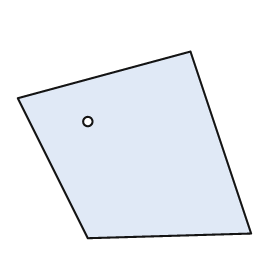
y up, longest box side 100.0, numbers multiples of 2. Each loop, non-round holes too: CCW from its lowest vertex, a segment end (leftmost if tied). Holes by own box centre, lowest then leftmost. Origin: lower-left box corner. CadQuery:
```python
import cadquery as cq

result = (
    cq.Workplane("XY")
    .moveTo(30.0, 0.0)
    .lineTo(100.0, 2.0)
    .lineTo(74.0, 80.0)
    .lineTo(0.0, 60.0)
    .close()
    .moveTo(30.0, 50.0)
    .circle(2.0)
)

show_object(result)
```